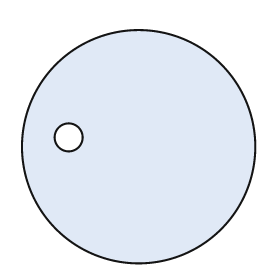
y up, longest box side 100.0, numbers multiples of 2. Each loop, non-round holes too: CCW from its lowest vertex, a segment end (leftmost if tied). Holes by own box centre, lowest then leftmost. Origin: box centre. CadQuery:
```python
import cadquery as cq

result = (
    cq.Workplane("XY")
    .moveTo(0.0, 0.0)
    .circle(50.0)
    .moveTo(-30.0, 4.0)
    .circle(6.0)
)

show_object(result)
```